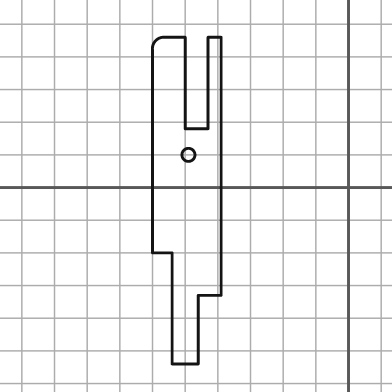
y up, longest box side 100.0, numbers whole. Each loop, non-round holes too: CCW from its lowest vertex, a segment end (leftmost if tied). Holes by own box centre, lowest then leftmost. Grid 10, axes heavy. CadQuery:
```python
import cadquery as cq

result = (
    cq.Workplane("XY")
    .moveTo(-54.0, -54.0)
    .lineTo(-46.0, -54.0)
    .lineTo(-46.0, -33.0)
    .lineTo(-39.0, -33.0)
    .lineTo(-39.0, 46.0)
    .lineTo(-43.0, 46.0)
    .lineTo(-43.0, 18.0)
    .lineTo(-50.0, 18.0)
    .lineTo(-50.0, 46.0)
    .lineTo(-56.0, 46.0)
    .threePointArc((-59.0, 45.0), (-60.0, 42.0))
    .lineTo(-60.0, -20.0)
    .lineTo(-54.0, -20.0)
    .close()
    .moveTo(-49.0, 10.0)
    .circle(2.0)
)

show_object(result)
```